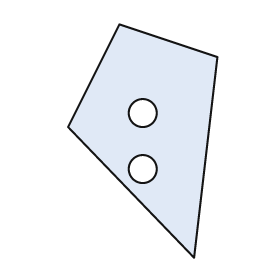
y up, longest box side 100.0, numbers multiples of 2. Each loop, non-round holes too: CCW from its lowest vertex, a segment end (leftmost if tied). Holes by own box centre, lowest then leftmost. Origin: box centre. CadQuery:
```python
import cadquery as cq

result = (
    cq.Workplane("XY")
    .moveTo(22.0, -50.0)
    .lineTo(32.0, 36.0)
    .lineTo(-10.0, 50.0)
    .lineTo(-32.0, 6.0)
    .close()
    .moveTo(0.0, -12.0)
    .circle(6.0)
    .moveTo(0.0, 12.0)
    .circle(6.0)
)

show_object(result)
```